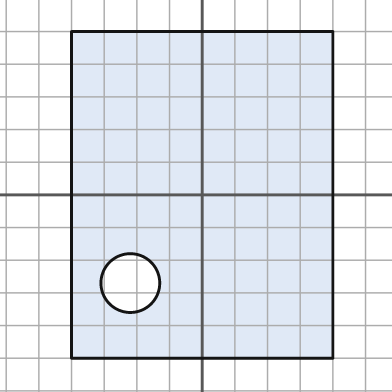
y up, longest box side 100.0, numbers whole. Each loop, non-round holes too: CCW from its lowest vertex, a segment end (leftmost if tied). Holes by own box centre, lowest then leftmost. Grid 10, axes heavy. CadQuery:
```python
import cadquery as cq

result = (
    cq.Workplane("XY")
    .moveTo(-40.0, -50.0)
    .lineTo(40.0, -50.0)
    .lineTo(40.0, 50.0)
    .lineTo(-40.0, 50.0)
    .close()
    .moveTo(-22.0, -27.0)
    .circle(9.0)
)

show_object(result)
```